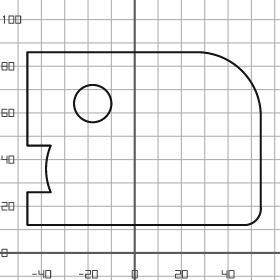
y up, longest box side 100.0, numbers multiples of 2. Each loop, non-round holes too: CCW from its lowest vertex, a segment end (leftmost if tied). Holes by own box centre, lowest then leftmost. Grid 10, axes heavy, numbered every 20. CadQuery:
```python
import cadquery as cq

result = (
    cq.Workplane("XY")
    .moveTo(-46.0, 12.0)
    .lineTo(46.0, 12.0)
    .threePointArc((52.0, 14.0), (54.0, 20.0))
    .lineTo(54.0, 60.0)
    .threePointArc((46.0, 78.0), (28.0, 86.0))
    .lineTo(-46.0, 86.0)
    .lineTo(-46.0, 46.0)
    .lineTo(-36.0, 46.0)
    .threePointArc((-38.0, 36.0), (-36.0, 26.0))
    .lineTo(-46.0, 26.0)
    .close()
    .moveTo(-18.0, 64.0)
    .circle(8.0)
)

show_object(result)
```